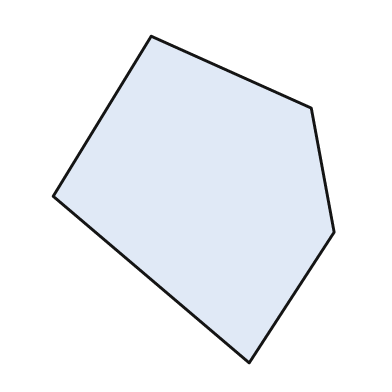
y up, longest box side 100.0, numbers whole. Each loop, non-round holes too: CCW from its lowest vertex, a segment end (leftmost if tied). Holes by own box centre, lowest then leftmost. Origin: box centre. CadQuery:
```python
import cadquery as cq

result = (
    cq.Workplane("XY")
    .moveTo(17.0, -50.0)
    .lineTo(43.0, -10.0)
    .lineTo(36.0, 28.0)
    .lineTo(-13.0, 50.0)
    .lineTo(-43.0, 1.0)
    .close()
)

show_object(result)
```